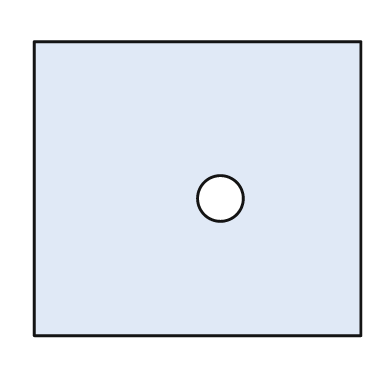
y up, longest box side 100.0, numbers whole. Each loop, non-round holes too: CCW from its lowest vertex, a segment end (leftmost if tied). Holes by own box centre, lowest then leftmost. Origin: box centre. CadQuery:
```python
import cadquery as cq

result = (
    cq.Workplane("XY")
    .moveTo(-50.0, -45.0)
    .lineTo(50.0, -45.0)
    .lineTo(50.0, 45.0)
    .lineTo(-50.0, 45.0)
    .close()
    .moveTo(7.0, -3.0)
    .circle(7.0)
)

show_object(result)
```